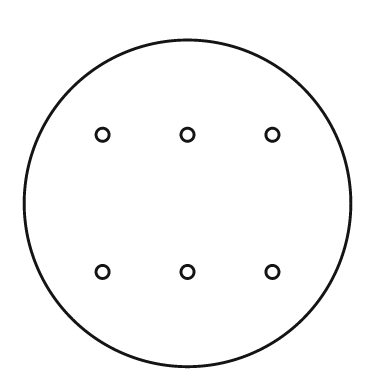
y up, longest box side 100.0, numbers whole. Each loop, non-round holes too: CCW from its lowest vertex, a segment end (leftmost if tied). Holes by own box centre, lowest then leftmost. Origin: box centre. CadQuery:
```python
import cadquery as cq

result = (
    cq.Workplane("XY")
    .moveTo(0.0, 0.0)
    .circle(50.0)
    .moveTo(-26.0, -21.0)
    .circle(2.0)
    .moveTo(0.0, -21.0)
    .circle(2.0)
    .moveTo(26.0, -21.0)
    .circle(2.0)
    .moveTo(-26.0, 21.0)
    .circle(2.0)
    .moveTo(0.0, 21.0)
    .circle(2.0)
    .moveTo(26.0, 21.0)
    .circle(2.0)
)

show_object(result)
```